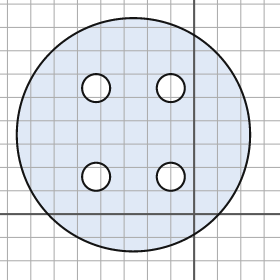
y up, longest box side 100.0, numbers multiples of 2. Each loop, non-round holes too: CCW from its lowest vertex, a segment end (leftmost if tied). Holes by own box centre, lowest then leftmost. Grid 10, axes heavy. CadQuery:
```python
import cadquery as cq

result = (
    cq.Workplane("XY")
    .moveTo(-26.0, 34.0)
    .circle(50.0)
    .moveTo(-42.0, 16.0)
    .circle(6.0)
    .moveTo(-10.0, 16.0)
    .circle(6.0)
    .moveTo(-42.0, 54.0)
    .circle(6.0)
    .moveTo(-10.0, 54.0)
    .circle(6.0)
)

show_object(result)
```